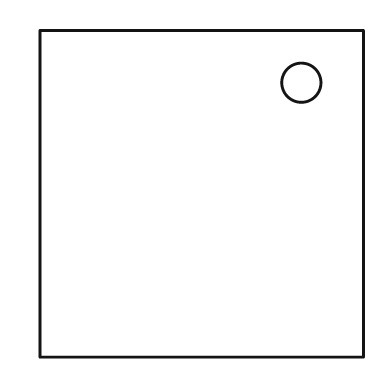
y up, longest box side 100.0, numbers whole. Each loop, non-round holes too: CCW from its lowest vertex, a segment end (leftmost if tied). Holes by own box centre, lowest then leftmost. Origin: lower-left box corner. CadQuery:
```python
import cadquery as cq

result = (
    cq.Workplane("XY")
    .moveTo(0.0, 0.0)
    .lineTo(99.0, 0.0)
    .lineTo(99.0, 100.0)
    .lineTo(0.0, 100.0)
    .close()
    .moveTo(80.0, 84.0)
    .circle(6.0)
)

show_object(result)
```